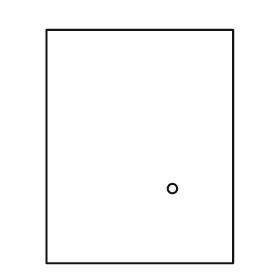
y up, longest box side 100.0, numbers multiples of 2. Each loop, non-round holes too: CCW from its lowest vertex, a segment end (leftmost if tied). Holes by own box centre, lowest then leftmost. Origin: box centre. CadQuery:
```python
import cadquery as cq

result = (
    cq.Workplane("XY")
    .moveTo(-40.0, -50.0)
    .lineTo(40.0, -50.0)
    .lineTo(40.0, 50.0)
    .lineTo(-40.0, 50.0)
    .close()
    .moveTo(14.0, -18.0)
    .circle(2.0)
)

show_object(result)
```